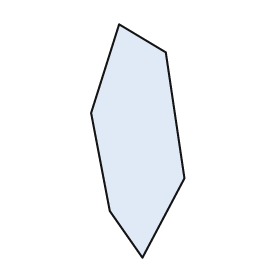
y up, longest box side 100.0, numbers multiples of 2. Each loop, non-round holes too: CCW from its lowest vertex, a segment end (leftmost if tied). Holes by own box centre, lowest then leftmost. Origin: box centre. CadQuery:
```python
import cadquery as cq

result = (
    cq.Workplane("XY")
    .moveTo(2.0, -50.0)
    .lineTo(20.0, -16.0)
    .lineTo(12.0, 38.0)
    .lineTo(-8.0, 50.0)
    .lineTo(-20.0, 12.0)
    .lineTo(-12.0, -30.0)
    .close()
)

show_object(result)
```